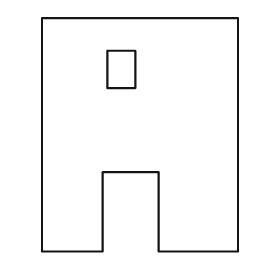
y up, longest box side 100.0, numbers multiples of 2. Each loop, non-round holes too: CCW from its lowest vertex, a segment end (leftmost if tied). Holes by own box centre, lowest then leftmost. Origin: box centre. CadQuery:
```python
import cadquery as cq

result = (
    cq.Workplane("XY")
    .moveTo(-42.0, -50.0)
    .lineTo(-16.0, -50.0)
    .lineTo(-16.0, -16.0)
    .lineTo(8.0, -16.0)
    .lineTo(8.0, -50.0)
    .lineTo(42.0, -50.0)
    .lineTo(42.0, 50.0)
    .lineTo(-42.0, 50.0)
    .close()
    .moveTo(-14.0, 20.0)
    .lineTo(-2.0, 20.0)
    .lineTo(-2.0, 36.0)
    .lineTo(-14.0, 36.0)
    .close()
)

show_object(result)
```